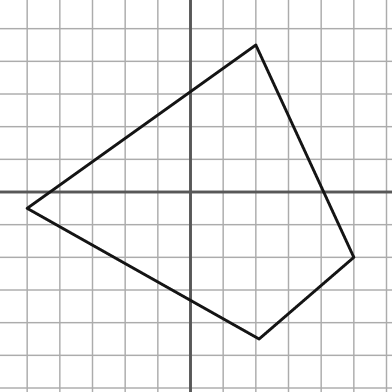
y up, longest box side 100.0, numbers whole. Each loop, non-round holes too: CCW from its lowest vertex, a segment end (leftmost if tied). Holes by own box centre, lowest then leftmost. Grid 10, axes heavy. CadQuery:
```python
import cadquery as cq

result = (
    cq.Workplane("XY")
    .moveTo(21.0, -45.0)
    .lineTo(50.0, -20.0)
    .lineTo(20.0, 45.0)
    .lineTo(-50.0, -5.0)
    .close()
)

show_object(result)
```